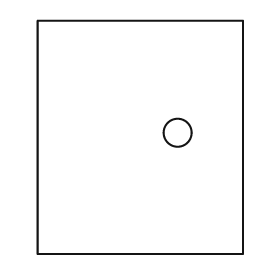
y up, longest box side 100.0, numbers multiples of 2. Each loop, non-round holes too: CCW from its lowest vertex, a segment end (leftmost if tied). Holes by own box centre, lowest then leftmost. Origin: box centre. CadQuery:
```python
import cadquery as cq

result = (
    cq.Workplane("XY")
    .moveTo(-44.0, -50.0)
    .lineTo(44.0, -50.0)
    .lineTo(44.0, 50.0)
    .lineTo(-44.0, 50.0)
    .close()
    .moveTo(16.0, 2.0)
    .circle(6.0)
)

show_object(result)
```